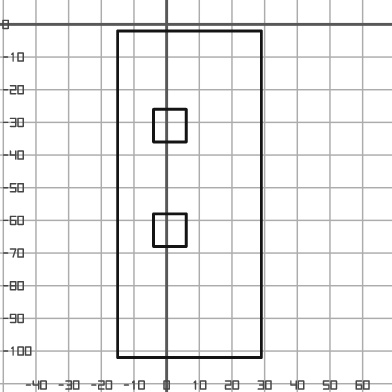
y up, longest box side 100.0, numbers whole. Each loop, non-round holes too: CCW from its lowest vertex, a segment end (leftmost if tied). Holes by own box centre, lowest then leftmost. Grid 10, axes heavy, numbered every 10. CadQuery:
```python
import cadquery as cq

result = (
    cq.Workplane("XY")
    .moveTo(-15.0, -102.0)
    .lineTo(29.0, -102.0)
    .lineTo(29.0, -2.0)
    .lineTo(-15.0, -2.0)
    .close()
    .moveTo(-4.0, -68.0)
    .lineTo(6.0, -68.0)
    .lineTo(6.0, -58.0)
    .lineTo(-4.0, -58.0)
    .close()
    .moveTo(-4.0, -36.0)
    .lineTo(6.0, -36.0)
    .lineTo(6.0, -26.0)
    .lineTo(-4.0, -26.0)
    .close()
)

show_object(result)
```